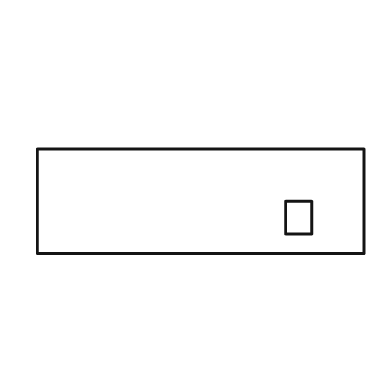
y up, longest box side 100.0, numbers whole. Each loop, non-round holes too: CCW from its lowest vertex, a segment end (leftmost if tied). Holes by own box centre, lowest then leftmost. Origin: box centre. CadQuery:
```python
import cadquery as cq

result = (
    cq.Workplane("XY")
    .moveTo(-50.0, -16.0)
    .lineTo(50.0, -16.0)
    .lineTo(50.0, 16.0)
    .lineTo(-50.0, 16.0)
    .close()
    .moveTo(26.0, -10.0)
    .lineTo(34.0, -10.0)
    .lineTo(34.0, 0.0)
    .lineTo(26.0, 0.0)
    .close()
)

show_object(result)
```